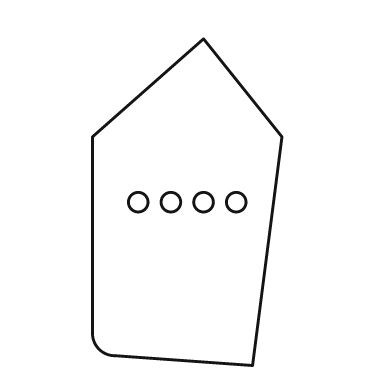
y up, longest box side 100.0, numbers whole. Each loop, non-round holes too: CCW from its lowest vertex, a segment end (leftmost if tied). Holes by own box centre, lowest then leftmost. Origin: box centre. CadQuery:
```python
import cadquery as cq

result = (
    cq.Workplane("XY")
    .moveTo(20.0, -50.0)
    .lineTo(29.0, 20.0)
    .lineTo(5.0, 50.0)
    .lineTo(-29.0, 20.0)
    .lineTo(-29.0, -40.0)
    .threePointArc((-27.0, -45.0), (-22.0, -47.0))
    .close()
    .moveTo(-15.0, 0.0)
    .circle(3.0)
    .moveTo(-5.0, 0.0)
    .circle(3.0)
    .moveTo(5.0, 0.0)
    .circle(3.0)
    .moveTo(15.0, 0.0)
    .circle(3.0)
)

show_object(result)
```